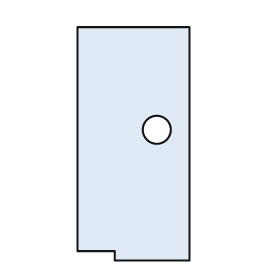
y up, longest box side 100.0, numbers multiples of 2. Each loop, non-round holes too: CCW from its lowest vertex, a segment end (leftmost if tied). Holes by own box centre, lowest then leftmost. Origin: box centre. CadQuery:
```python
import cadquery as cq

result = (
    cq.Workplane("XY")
    .moveTo(-8.0, -50.0)
    .lineTo(24.0, -50.0)
    .lineTo(24.0, 50.0)
    .lineTo(-24.0, 50.0)
    .lineTo(-24.0, -46.0)
    .lineTo(-8.0, -46.0)
    .close()
    .moveTo(10.0, 6.0)
    .circle(6.0)
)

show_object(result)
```